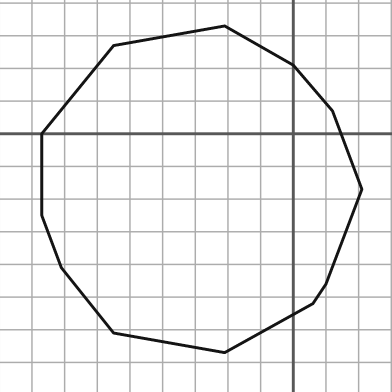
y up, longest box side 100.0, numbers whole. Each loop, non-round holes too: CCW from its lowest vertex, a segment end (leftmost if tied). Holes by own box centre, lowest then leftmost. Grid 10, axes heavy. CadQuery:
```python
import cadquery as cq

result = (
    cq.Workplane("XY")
    .moveTo(-21.0, -67.0)
    .lineTo(6.0, -52.0)
    .lineTo(10.0, -46.0)
    .lineTo(21.0, -17.0)
    .lineTo(12.0, 7.0)
    .lineTo(0.0, 21.0)
    .lineTo(-21.0, 33.0)
    .lineTo(-55.0, 27.0)
    .lineTo(-77.0, 0.0)
    .lineTo(-77.0, -25.0)
    .lineTo(-71.0, -41.0)
    .lineTo(-55.0, -61.0)
    .close()
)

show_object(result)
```